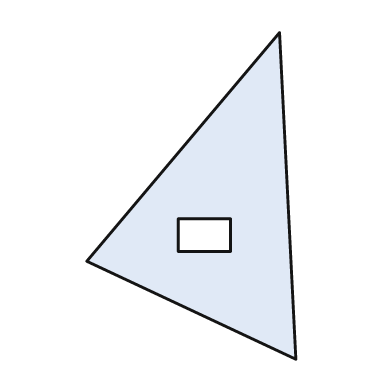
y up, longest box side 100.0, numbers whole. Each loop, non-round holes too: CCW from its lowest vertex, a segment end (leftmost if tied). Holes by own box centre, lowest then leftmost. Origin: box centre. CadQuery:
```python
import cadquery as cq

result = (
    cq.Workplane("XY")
    .moveTo(32.0, -50.0)
    .lineTo(27.0, 50.0)
    .lineTo(-32.0, -20.0)
    .close()
    .moveTo(-4.0, -17.0)
    .lineTo(12.0, -17.0)
    .lineTo(12.0, -7.0)
    .lineTo(-4.0, -7.0)
    .close()
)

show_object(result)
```